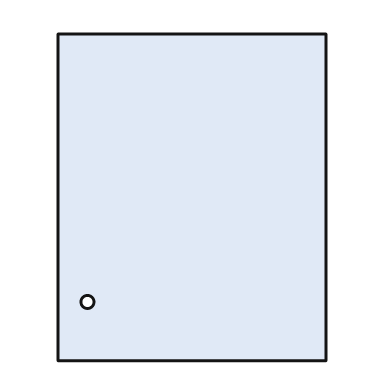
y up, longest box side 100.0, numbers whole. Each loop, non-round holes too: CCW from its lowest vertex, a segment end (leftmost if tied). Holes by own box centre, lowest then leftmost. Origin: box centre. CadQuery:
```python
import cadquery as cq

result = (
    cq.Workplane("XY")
    .moveTo(-41.0, -50.0)
    .lineTo(41.0, -50.0)
    .lineTo(41.0, 50.0)
    .lineTo(-41.0, 50.0)
    .close()
    .moveTo(-32.0, -32.0)
    .circle(2.0)
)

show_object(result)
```